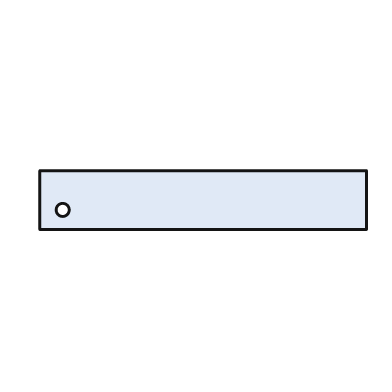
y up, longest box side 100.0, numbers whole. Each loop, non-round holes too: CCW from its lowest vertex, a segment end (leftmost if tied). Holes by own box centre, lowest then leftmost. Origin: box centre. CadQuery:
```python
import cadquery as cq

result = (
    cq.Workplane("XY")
    .moveTo(-50.0, -9.0)
    .lineTo(50.0, -9.0)
    .lineTo(50.0, 9.0)
    .lineTo(-50.0, 9.0)
    .close()
    .moveTo(-43.0, -3.0)
    .circle(2.0)
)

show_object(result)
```